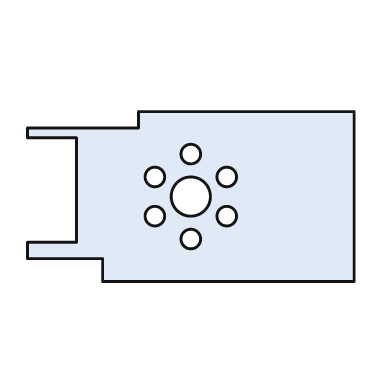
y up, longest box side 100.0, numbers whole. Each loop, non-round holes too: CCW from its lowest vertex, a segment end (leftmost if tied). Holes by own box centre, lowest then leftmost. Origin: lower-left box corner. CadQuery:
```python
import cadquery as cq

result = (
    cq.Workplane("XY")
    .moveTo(23.0, 0.0)
    .lineTo(100.0, 0.0)
    .lineTo(100.0, 52.0)
    .lineTo(34.0, 52.0)
    .lineTo(34.0, 47.0)
    .lineTo(0.0, 47.0)
    .lineTo(0.0, 44.0)
    .lineTo(15.0, 44.0)
    .lineTo(15.0, 12.0)
    .lineTo(0.0, 12.0)
    .lineTo(0.0, 7.0)
    .lineTo(23.0, 7.0)
    .close()
    .moveTo(50.0, 13.0)
    .circle(3.0)
    .moveTo(39.0, 20.0)
    .circle(3.0)
    .moveTo(61.0, 20.0)
    .circle(3.0)
    .moveTo(50.0, 26.0)
    .circle(6.0)
    .moveTo(39.0, 32.0)
    .circle(3.0)
    .moveTo(61.0, 32.0)
    .circle(3.0)
    .moveTo(50.0, 39.0)
    .circle(3.0)
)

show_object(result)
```